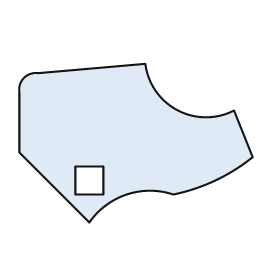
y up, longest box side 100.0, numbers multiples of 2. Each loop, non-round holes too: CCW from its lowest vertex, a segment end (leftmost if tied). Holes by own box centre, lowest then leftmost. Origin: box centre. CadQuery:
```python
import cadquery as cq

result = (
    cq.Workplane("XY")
    .moveTo(-20.0, -34.0)
    .threePointArc((-4.0, -22.0), (16.0, -22.0))
    .threePointArc((34.0, -16.0), (50.0, -6.0))
    .lineTo(42.0, 14.0)
    .threePointArc((18.0, 14.0), (4.0, 34.0))
    .lineTo(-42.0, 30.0)
    .threePointArc((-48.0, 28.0), (-50.0, 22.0))
    .lineTo(-50.0, -4.0)
    .close()
    .moveTo(-26.0, -22.0)
    .lineTo(-14.0, -22.0)
    .lineTo(-14.0, -10.0)
    .lineTo(-26.0, -10.0)
    .close()
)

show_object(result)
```